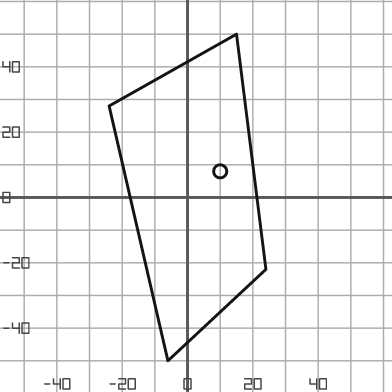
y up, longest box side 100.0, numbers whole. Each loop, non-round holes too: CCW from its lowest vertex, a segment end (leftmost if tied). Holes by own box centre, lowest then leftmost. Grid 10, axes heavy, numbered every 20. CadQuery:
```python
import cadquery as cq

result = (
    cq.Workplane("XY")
    .moveTo(-6.0, -50.0)
    .lineTo(24.0, -22.0)
    .lineTo(15.0, 50.0)
    .lineTo(-24.0, 28.0)
    .close()
    .moveTo(10.0, 8.0)
    .circle(2.0)
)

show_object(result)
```